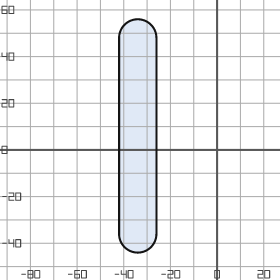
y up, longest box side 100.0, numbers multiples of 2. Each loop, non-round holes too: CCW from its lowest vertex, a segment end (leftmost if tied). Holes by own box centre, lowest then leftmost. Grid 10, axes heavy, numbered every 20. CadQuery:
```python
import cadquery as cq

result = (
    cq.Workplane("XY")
    .moveTo(-42.0, -36.0)
    .threePointArc((-34.0, -44.0), (-26.0, -36.0))
    .lineTo(-26.0, 48.0)
    .threePointArc((-34.0, 56.0), (-42.0, 48.0))
    .close()
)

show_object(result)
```